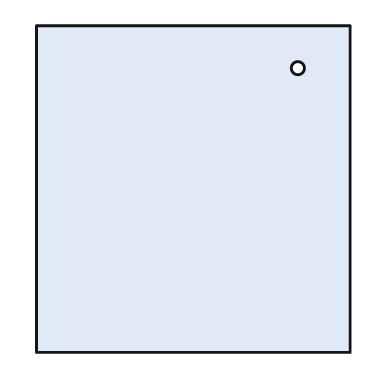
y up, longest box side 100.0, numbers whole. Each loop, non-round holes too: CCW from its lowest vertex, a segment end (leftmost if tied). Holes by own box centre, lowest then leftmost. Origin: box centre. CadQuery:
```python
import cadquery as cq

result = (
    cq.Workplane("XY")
    .moveTo(-48.0, -50.0)
    .lineTo(48.0, -50.0)
    .lineTo(48.0, 50.0)
    .lineTo(-48.0, 50.0)
    .close()
    .moveTo(32.0, 37.0)
    .circle(2.0)
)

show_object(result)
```